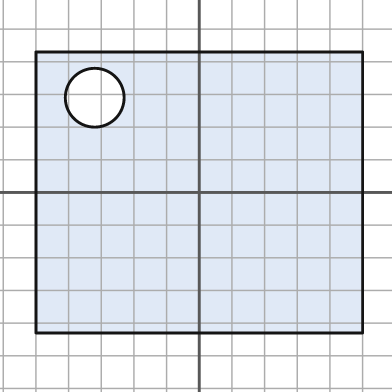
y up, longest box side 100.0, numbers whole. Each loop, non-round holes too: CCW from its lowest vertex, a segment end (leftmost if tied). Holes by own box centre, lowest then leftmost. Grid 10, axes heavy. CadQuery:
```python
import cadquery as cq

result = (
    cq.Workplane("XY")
    .moveTo(-50.0, -43.0)
    .lineTo(50.0, -43.0)
    .lineTo(50.0, 43.0)
    .lineTo(-50.0, 43.0)
    .close()
    .moveTo(-32.0, 29.0)
    .circle(9.0)
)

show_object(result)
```